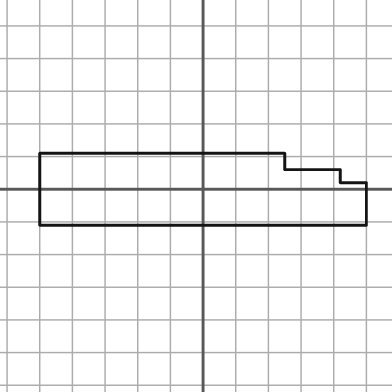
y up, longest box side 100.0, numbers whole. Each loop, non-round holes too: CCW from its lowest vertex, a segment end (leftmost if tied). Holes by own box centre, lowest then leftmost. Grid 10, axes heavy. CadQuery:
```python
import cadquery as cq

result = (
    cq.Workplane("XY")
    .moveTo(-50.0, -11.0)
    .lineTo(50.0, -11.0)
    .lineTo(50.0, 2.0)
    .lineTo(42.0, 2.0)
    .lineTo(42.0, 6.0)
    .lineTo(25.0, 6.0)
    .lineTo(25.0, 11.0)
    .lineTo(-50.0, 11.0)
    .close()
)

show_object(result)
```